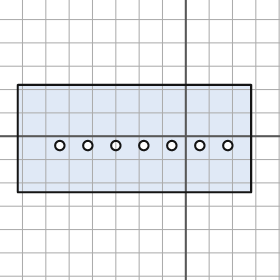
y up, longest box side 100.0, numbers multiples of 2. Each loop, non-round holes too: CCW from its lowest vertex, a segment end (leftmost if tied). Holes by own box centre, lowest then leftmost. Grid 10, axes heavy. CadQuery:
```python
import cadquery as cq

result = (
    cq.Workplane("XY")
    .moveTo(-72.0, -24.0)
    .lineTo(28.0, -24.0)
    .lineTo(28.0, 22.0)
    .lineTo(-72.0, 22.0)
    .close()
    .moveTo(-54.0, -4.0)
    .circle(2.0)
    .moveTo(-42.0, -4.0)
    .circle(2.0)
    .moveTo(-30.0, -4.0)
    .circle(2.0)
    .moveTo(-18.0, -4.0)
    .circle(2.0)
    .moveTo(-6.0, -4.0)
    .circle(2.0)
    .moveTo(6.0, -4.0)
    .circle(2.0)
    .moveTo(18.0, -4.0)
    .circle(2.0)
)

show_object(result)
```